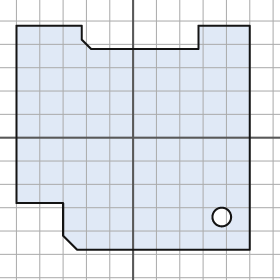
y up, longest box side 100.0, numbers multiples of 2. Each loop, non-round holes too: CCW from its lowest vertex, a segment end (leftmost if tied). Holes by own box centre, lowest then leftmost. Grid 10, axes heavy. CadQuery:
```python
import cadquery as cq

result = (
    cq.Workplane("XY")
    .moveTo(-24.0, -48.0)
    .lineTo(50.0, -48.0)
    .lineTo(50.0, 48.0)
    .lineTo(28.0, 48.0)
    .lineTo(28.0, 38.0)
    .lineTo(-18.0, 38.0)
    .lineTo(-22.0, 42.0)
    .lineTo(-22.0, 48.0)
    .lineTo(-50.0, 48.0)
    .lineTo(-50.0, -28.0)
    .lineTo(-30.0, -28.0)
    .lineTo(-30.0, -42.0)
    .close()
    .moveTo(38.0, -34.0)
    .circle(4.0)
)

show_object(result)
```